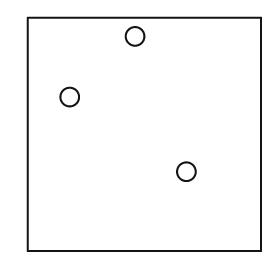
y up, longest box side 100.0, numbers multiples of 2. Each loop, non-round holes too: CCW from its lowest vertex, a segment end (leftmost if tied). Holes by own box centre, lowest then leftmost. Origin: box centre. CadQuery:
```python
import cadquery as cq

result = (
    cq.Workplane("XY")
    .moveTo(-50.0, -50.0)
    .lineTo(50.0, -50.0)
    .lineTo(50.0, 50.0)
    .lineTo(-50.0, 50.0)
    .close()
    .moveTo(18.0, -16.0)
    .circle(4.0)
    .moveTo(-32.0, 16.0)
    .circle(4.0)
    .moveTo(-4.0, 42.0)
    .circle(4.0)
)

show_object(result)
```